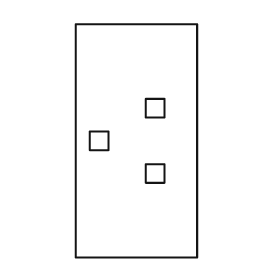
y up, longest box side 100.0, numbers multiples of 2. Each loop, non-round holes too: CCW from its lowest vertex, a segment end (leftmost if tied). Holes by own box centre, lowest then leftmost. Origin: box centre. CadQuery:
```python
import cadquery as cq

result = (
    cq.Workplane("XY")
    .moveTo(-26.0, -50.0)
    .lineTo(26.0, -50.0)
    .lineTo(26.0, 50.0)
    .lineTo(-26.0, 50.0)
    .close()
    .moveTo(4.0, -18.0)
    .lineTo(12.0, -18.0)
    .lineTo(12.0, -10.0)
    .lineTo(4.0, -10.0)
    .close()
    .moveTo(-20.0, -4.0)
    .lineTo(-12.0, -4.0)
    .lineTo(-12.0, 4.0)
    .lineTo(-20.0, 4.0)
    .close()
    .moveTo(4.0, 10.0)
    .lineTo(12.0, 10.0)
    .lineTo(12.0, 18.0)
    .lineTo(4.0, 18.0)
    .close()
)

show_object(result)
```